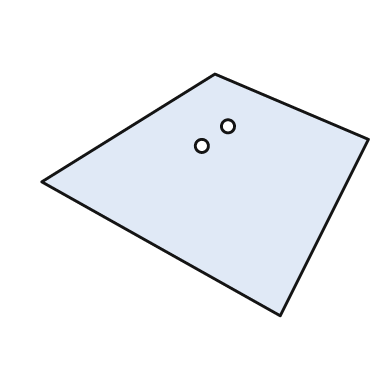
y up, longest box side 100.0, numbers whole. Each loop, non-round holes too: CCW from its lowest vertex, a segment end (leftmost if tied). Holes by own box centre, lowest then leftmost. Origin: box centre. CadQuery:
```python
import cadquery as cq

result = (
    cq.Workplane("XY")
    .moveTo(23.0, -37.0)
    .lineTo(50.0, 17.0)
    .lineTo(3.0, 37.0)
    .lineTo(-50.0, 4.0)
    .close()
    .moveTo(-1.0, 15.0)
    .circle(2.0)
    .moveTo(7.0, 21.0)
    .circle(2.0)
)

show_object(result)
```